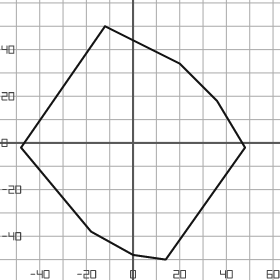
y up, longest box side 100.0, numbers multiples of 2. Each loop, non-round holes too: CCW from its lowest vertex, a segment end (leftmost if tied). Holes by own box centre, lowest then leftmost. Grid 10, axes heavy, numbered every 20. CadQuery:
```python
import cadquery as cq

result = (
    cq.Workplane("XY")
    .moveTo(14.0, -50.0)
    .lineTo(48.0, -2.0)
    .lineTo(36.0, 18.0)
    .lineTo(20.0, 34.0)
    .lineTo(-12.0, 50.0)
    .lineTo(-48.0, -2.0)
    .lineTo(-18.0, -38.0)
    .lineTo(0.0, -48.0)
    .close()
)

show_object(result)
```